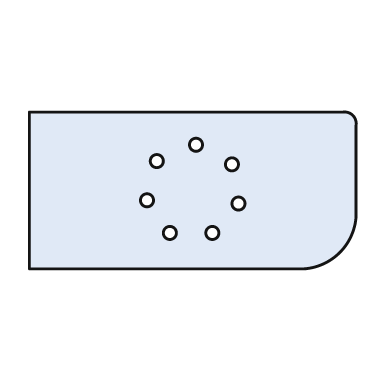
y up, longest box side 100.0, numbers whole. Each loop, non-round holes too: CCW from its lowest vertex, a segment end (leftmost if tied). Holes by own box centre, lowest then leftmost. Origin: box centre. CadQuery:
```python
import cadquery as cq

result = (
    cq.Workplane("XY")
    .moveTo(-50.0, -24.0)
    .lineTo(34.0, -24.0)
    .threePointArc((45.0, -19.0), (50.0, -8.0))
    .lineTo(50.0, 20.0)
    .threePointArc((49.0, 23.0), (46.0, 24.0))
    .lineTo(-50.0, 24.0)
    .close()
    .moveTo(-7.0, -13.0)
    .circle(2.0)
    .moveTo(6.0, -13.0)
    .circle(2.0)
    .moveTo(14.0, -4.0)
    .circle(2.0)
    .moveTo(-14.0, -3.0)
    .circle(2.0)
    .moveTo(12.0, 8.0)
    .circle(2.0)
    .moveTo(-11.0, 9.0)
    .circle(2.0)
    .moveTo(1.0, 14.0)
    .circle(2.0)
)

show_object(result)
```